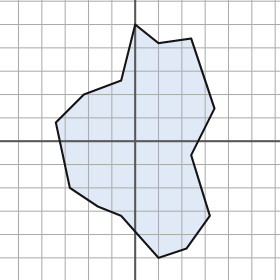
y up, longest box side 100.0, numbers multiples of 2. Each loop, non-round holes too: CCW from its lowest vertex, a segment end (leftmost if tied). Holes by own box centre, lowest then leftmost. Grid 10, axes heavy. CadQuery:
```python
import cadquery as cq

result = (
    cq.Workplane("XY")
    .moveTo(10.0, -50.0)
    .lineTo(22.0, -46.0)
    .lineTo(32.0, -32.0)
    .lineTo(24.0, -6.0)
    .lineTo(34.0, 14.0)
    .lineTo(24.0, 44.0)
    .lineTo(10.0, 42.0)
    .lineTo(0.0, 50.0)
    .lineTo(-6.0, 26.0)
    .lineTo(-22.0, 20.0)
    .lineTo(-34.0, 8.0)
    .lineTo(-28.0, -20.0)
    .lineTo(-16.0, -28.0)
    .lineTo(-6.0, -32.0)
    .close()
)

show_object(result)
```